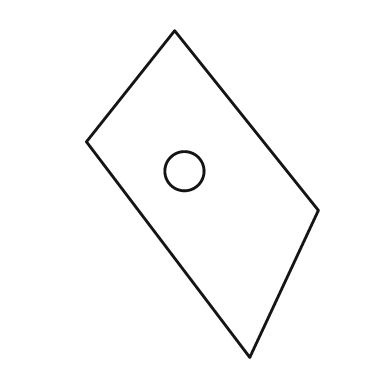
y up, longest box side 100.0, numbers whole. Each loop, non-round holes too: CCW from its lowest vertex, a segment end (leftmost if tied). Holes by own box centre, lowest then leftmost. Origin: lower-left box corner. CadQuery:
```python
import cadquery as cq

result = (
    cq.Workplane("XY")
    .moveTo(50.0, 0.0)
    .lineTo(71.0, 45.0)
    .lineTo(27.0, 100.0)
    .lineTo(0.0, 66.0)
    .close()
    .moveTo(30.0, 57.0)
    .circle(6.0)
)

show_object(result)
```